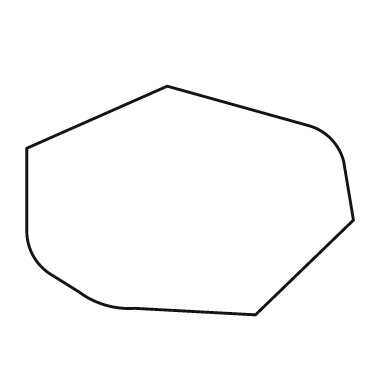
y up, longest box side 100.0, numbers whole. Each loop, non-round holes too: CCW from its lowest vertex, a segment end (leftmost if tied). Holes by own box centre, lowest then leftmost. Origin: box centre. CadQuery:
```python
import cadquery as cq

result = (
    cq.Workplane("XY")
    .moveTo(20.0, -35.0)
    .lineTo(50.0, -6.0)
    .lineTo(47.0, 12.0)
    .threePointArc((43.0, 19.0), (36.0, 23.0))
    .lineTo(-7.0, 35.0)
    .lineTo(-50.0, 16.0)
    .lineTo(-50.0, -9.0)
    .threePointArc((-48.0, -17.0), (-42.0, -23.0))
    .lineTo(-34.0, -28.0)
    .threePointArc((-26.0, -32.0), (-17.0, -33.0))
    .close()
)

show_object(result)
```